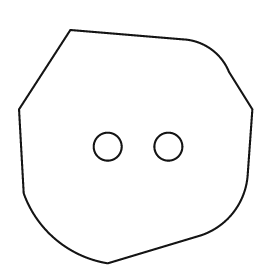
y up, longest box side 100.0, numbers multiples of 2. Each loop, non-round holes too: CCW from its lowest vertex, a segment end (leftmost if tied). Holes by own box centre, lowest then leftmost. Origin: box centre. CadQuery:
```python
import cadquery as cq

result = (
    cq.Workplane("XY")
    .moveTo(-12.0, -50.0)
    .lineTo(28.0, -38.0)
    .threePointArc((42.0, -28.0), (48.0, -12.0))
    .lineTo(50.0, 16.0)
    .lineTo(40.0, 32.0)
    .threePointArc((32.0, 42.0), (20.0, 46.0))
    .lineTo(-28.0, 50.0)
    .lineTo(-50.0, 16.0)
    .lineTo(-48.0, -20.0)
    .threePointArc((-34.0, -40.0), (-12.0, -50.0))
    .close()
    .moveTo(-12.0, 0.0)
    .circle(6.0)
    .moveTo(14.0, 0.0)
    .circle(6.0)
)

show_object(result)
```